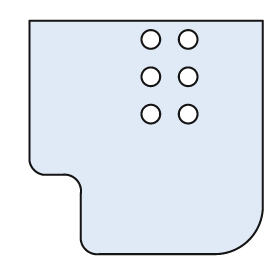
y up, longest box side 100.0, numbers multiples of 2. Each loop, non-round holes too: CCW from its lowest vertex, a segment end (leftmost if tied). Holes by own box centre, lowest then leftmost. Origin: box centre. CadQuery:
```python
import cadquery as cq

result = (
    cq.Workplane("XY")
    .moveTo(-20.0, -50.0)
    .lineTo(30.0, -50.0)
    .threePointArc((44.0, -44.0), (50.0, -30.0))
    .lineTo(50.0, 50.0)
    .lineTo(-50.0, 50.0)
    .lineTo(-50.0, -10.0)
    .threePointArc((-48.0, -14.0), (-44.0, -16.0))
    .lineTo(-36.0, -16.0)
    .threePointArc((-30.0, -18.0), (-28.0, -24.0))
    .lineTo(-28.0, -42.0)
    .threePointArc((-26.0, -48.0), (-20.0, -50.0))
    .close()
    .moveTo(2.0, 10.0)
    .circle(4.0)
    .moveTo(18.0, 10.0)
    .circle(4.0)
    .moveTo(2.0, 26.0)
    .circle(4.0)
    .moveTo(18.0, 26.0)
    .circle(4.0)
    .moveTo(2.0, 42.0)
    .circle(4.0)
    .moveTo(18.0, 42.0)
    .circle(4.0)
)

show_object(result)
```